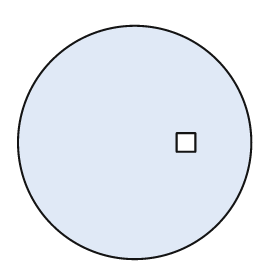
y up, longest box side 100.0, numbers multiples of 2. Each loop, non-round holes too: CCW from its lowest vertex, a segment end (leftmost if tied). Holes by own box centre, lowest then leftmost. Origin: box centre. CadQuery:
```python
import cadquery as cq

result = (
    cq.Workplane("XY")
    .moveTo(0.0, 0.0)
    .circle(50.0)
    .moveTo(18.0, -4.0)
    .lineTo(26.0, -4.0)
    .lineTo(26.0, 4.0)
    .lineTo(18.0, 4.0)
    .close()
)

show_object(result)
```